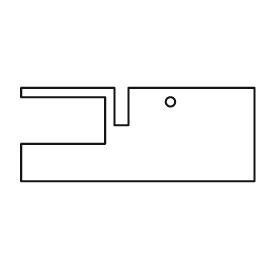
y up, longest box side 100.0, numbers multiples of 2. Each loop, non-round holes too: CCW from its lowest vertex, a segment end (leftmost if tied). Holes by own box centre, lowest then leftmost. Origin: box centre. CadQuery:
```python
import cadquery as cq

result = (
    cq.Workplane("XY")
    .moveTo(-50.0, -20.0)
    .lineTo(50.0, -20.0)
    .lineTo(50.0, 20.0)
    .lineTo(-4.0, 20.0)
    .lineTo(-4.0, 4.0)
    .lineTo(-10.0, 4.0)
    .lineTo(-10.0, 20.0)
    .lineTo(-50.0, 20.0)
    .lineTo(-50.0, 16.0)
    .lineTo(-14.0, 16.0)
    .lineTo(-14.0, -4.0)
    .lineTo(-50.0, -4.0)
    .close()
    .moveTo(14.0, 14.0)
    .circle(2.0)
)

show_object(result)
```